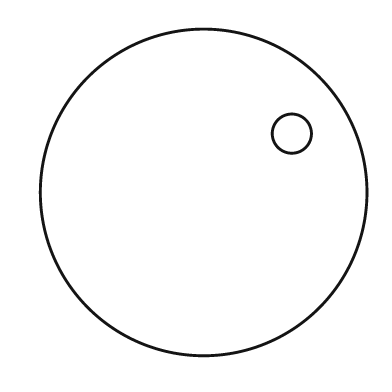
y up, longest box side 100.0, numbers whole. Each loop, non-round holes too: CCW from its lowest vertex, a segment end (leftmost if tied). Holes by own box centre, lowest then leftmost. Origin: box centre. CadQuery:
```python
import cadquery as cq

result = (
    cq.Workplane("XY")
    .moveTo(0.0, 0.0)
    .circle(50.0)
    .moveTo(27.0, 18.0)
    .circle(6.0)
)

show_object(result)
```